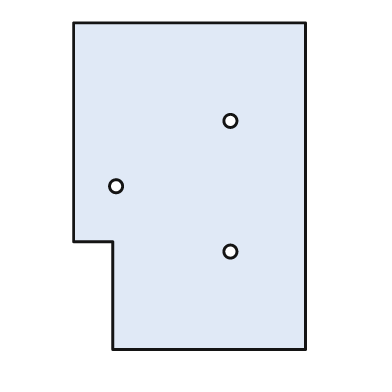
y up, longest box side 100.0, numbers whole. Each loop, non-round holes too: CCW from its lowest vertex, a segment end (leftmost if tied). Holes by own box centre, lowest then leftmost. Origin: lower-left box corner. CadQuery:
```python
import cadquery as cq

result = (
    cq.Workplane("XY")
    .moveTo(12.0, 0.0)
    .lineTo(71.0, 0.0)
    .lineTo(71.0, 100.0)
    .lineTo(0.0, 100.0)
    .lineTo(0.0, 33.0)
    .lineTo(12.0, 33.0)
    .close()
    .moveTo(48.0, 30.0)
    .circle(2.0)
    .moveTo(13.0, 50.0)
    .circle(2.0)
    .moveTo(48.0, 70.0)
    .circle(2.0)
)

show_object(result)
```